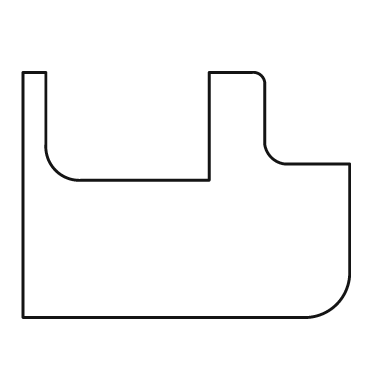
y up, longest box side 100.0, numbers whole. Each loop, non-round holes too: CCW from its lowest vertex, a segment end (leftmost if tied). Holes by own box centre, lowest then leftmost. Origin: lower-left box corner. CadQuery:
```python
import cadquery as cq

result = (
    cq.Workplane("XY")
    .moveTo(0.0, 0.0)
    .lineTo(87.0, 0.0)
    .threePointArc((96.0, 4.0), (100.0, 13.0))
    .lineTo(100.0, 47.0)
    .lineTo(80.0, 47.0)
    .threePointArc((76.0, 49.0), (74.0, 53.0))
    .lineTo(74.0, 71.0)
    .threePointArc((73.0, 74.0), (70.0, 75.0))
    .lineTo(57.0, 75.0)
    .lineTo(57.0, 42.0)
    .lineTo(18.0, 42.0)
    .threePointArc((10.0, 45.0), (7.0, 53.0))
    .lineTo(7.0, 75.0)
    .lineTo(0.0, 75.0)
    .close()
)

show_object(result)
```